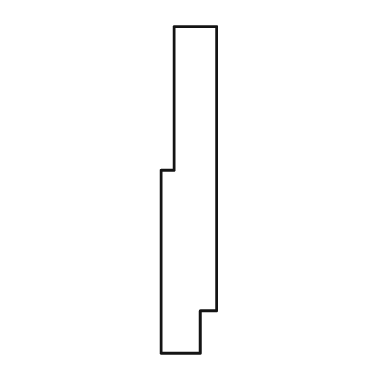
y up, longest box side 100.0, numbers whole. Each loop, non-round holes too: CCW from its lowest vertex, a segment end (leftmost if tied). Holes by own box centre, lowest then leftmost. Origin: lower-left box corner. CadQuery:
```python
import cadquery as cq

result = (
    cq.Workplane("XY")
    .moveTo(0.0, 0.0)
    .lineTo(12.0, 0.0)
    .lineTo(12.0, 13.0)
    .lineTo(17.0, 13.0)
    .lineTo(17.0, 100.0)
    .lineTo(4.0, 100.0)
    .lineTo(4.0, 56.0)
    .lineTo(0.0, 56.0)
    .close()
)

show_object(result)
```